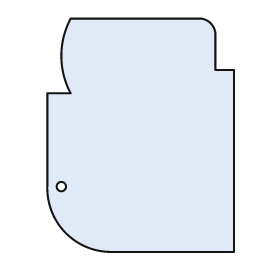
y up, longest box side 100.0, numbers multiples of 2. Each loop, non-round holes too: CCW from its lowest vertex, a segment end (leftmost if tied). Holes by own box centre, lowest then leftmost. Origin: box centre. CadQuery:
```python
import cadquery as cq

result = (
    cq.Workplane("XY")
    .moveTo(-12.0, -50.0)
    .lineTo(40.0, -50.0)
    .lineTo(40.0, 28.0)
    .lineTo(32.0, 28.0)
    .lineTo(32.0, 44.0)
    .threePointArc((30.0, 48.0), (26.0, 50.0))
    .lineTo(-30.0, 50.0)
    .threePointArc((-34.0, 34.0), (-30.0, 18.0))
    .lineTo(-40.0, 18.0)
    .lineTo(-40.0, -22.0)
    .threePointArc((-32.0, -42.0), (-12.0, -50.0))
    .close()
    .moveTo(-34.0, -22.0)
    .circle(2.0)
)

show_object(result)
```